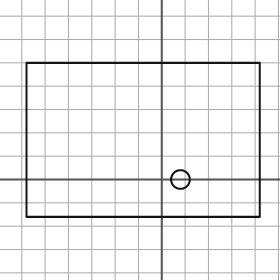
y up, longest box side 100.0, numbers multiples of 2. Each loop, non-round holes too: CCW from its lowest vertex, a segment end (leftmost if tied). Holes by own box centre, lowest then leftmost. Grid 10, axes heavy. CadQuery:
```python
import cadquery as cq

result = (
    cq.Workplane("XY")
    .moveTo(-58.0, -16.0)
    .lineTo(42.0, -16.0)
    .lineTo(42.0, 50.0)
    .lineTo(-58.0, 50.0)
    .close()
    .moveTo(8.0, 0.0)
    .circle(4.0)
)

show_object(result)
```